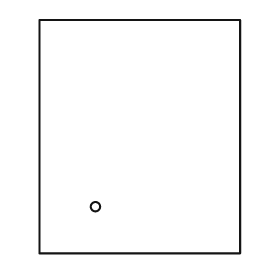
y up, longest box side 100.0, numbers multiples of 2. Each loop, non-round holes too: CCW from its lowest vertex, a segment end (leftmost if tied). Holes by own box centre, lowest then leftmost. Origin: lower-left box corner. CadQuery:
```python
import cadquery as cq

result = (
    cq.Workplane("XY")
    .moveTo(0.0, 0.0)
    .lineTo(86.0, 0.0)
    .lineTo(86.0, 100.0)
    .lineTo(0.0, 100.0)
    .close()
    .moveTo(24.0, 20.0)
    .circle(2.0)
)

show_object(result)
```